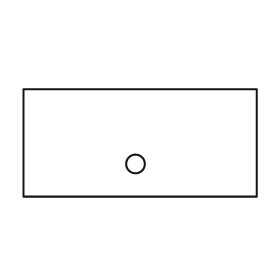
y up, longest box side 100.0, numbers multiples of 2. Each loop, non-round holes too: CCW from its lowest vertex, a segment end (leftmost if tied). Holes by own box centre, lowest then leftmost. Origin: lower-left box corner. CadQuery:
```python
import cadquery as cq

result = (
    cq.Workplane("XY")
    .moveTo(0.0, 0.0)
    .lineTo(100.0, 0.0)
    .lineTo(100.0, 46.0)
    .lineTo(0.0, 46.0)
    .close()
    .moveTo(48.0, 14.0)
    .circle(4.0)
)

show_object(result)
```